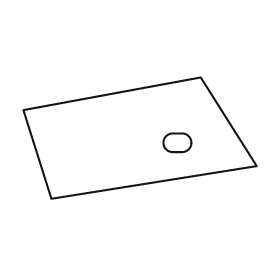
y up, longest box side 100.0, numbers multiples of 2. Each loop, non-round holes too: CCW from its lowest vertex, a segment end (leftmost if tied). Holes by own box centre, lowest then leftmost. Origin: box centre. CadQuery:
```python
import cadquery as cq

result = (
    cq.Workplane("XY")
    .moveTo(-38.0, -26.0)
    .lineTo(50.0, -12.0)
    .lineTo(26.0, 26.0)
    .lineTo(-50.0, 12.0)
    .close()
    .moveTo(14.0, -6.0)
    .lineTo(18.0, -6.0)
    .threePointArc((22.0, -2.0), (18.0, 2.0))
    .lineTo(14.0, 2.0)
    .threePointArc((10.0, -2.0), (14.0, -6.0))
    .close()
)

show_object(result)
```